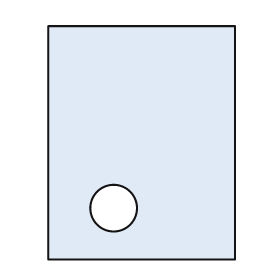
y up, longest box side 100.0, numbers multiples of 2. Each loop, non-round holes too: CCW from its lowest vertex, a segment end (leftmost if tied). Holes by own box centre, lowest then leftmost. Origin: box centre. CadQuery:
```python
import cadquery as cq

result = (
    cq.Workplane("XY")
    .moveTo(-40.0, -50.0)
    .lineTo(40.0, -50.0)
    .lineTo(40.0, 50.0)
    .lineTo(-40.0, 50.0)
    .close()
    .moveTo(-12.0, -28.0)
    .circle(10.0)
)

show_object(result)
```